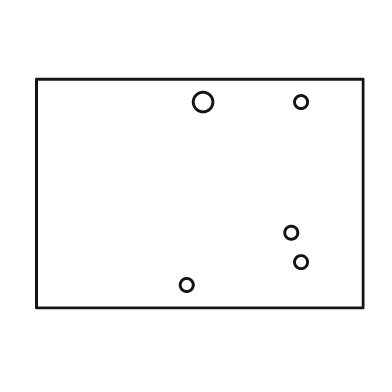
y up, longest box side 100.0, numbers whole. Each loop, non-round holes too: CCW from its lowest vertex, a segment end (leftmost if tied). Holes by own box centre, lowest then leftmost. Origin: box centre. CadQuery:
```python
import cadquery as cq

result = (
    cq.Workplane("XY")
    .moveTo(-50.0, -35.0)
    .lineTo(50.0, -35.0)
    .lineTo(50.0, 35.0)
    .lineTo(-50.0, 35.0)
    .close()
    .moveTo(-4.0, -28.0)
    .circle(2.0)
    .moveTo(31.0, -21.0)
    .circle(2.0)
    .moveTo(28.0, -12.0)
    .circle(2.0)
    .moveTo(1.0, 28.0)
    .circle(3.0)
    .moveTo(31.0, 28.0)
    .circle(2.0)
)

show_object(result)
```